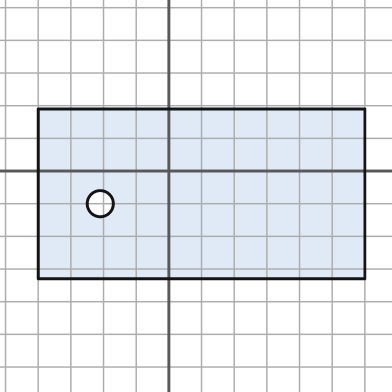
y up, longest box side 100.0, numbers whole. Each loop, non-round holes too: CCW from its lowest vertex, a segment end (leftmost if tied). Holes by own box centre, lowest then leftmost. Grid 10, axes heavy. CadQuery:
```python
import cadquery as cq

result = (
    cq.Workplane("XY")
    .moveTo(-40.0, -33.0)
    .lineTo(60.0, -33.0)
    .lineTo(60.0, 19.0)
    .lineTo(-40.0, 19.0)
    .close()
    .moveTo(-21.0, -10.0)
    .circle(4.0)
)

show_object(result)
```